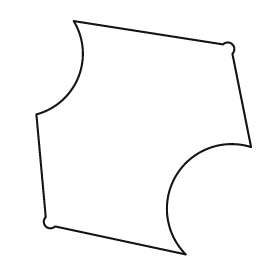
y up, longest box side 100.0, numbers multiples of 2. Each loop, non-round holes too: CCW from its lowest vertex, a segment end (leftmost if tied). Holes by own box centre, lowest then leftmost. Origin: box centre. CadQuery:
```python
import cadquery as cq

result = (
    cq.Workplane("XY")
    .moveTo(18.0, -50.0)
    .threePointArc((14.0, -16.0), (46.0, -4.0))
    .lineTo(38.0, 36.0)
    .threePointArc((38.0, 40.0), (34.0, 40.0))
    .lineTo(-30.0, 50.0)
    .threePointArc((-28.0, 26.0), (-46.0, 10.0))
    .lineTo(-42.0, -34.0)
    .threePointArc((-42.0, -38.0), (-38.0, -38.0))
    .close()
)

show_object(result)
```